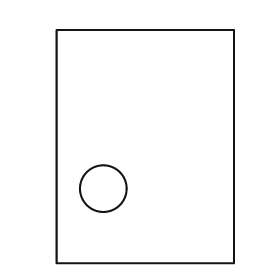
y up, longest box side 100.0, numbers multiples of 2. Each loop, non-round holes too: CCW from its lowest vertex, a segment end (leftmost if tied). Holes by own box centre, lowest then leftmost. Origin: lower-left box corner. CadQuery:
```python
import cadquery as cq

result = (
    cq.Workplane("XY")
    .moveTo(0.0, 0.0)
    .lineTo(76.0, 0.0)
    .lineTo(76.0, 100.0)
    .lineTo(0.0, 100.0)
    .close()
    .moveTo(20.0, 32.0)
    .circle(10.0)
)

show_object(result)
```